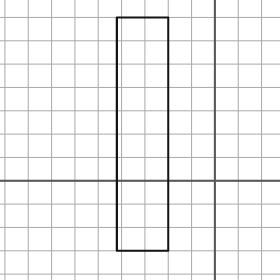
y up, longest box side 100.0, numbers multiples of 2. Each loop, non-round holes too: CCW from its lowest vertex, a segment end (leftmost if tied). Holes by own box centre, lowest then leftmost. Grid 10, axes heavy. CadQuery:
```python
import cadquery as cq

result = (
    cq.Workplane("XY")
    .moveTo(-42.0, -30.0)
    .lineTo(-20.0, -30.0)
    .lineTo(-20.0, 70.0)
    .lineTo(-42.0, 70.0)
    .close()
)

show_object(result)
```